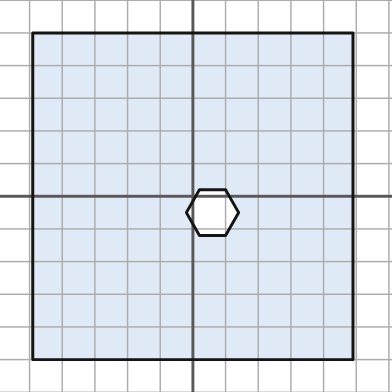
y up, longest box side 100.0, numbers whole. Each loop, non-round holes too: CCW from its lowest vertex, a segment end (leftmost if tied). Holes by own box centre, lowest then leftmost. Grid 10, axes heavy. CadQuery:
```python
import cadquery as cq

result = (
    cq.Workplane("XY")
    .moveTo(-49.0, -50.0)
    .lineTo(49.0, -50.0)
    .lineTo(49.0, 50.0)
    .lineTo(-49.0, 50.0)
    .close()
    .moveTo(2.0, -12.0)
    .lineTo(10.0, -12.0)
    .lineTo(14.0, -5.0)
    .lineTo(10.0, 2.0)
    .lineTo(2.0, 2.0)
    .lineTo(-2.0, -5.0)
    .close()
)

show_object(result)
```